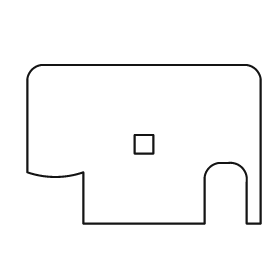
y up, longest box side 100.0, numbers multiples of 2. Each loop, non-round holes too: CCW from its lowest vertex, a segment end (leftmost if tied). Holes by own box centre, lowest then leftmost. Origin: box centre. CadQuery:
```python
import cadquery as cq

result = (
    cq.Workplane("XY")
    .moveTo(-26.0, -34.0)
    .lineTo(26.0, -34.0)
    .lineTo(26.0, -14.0)
    .threePointArc((28.0, -10.0), (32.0, -8.0))
    .lineTo(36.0, -8.0)
    .threePointArc((42.0, -10.0), (44.0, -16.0))
    .lineTo(44.0, -34.0)
    .lineTo(50.0, -34.0)
    .lineTo(50.0, 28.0)
    .threePointArc((48.0, 32.0), (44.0, 34.0))
    .lineTo(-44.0, 34.0)
    .threePointArc((-48.0, 32.0), (-50.0, 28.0))
    .lineTo(-50.0, -12.0)
    .threePointArc((-38.0, -14.0), (-26.0, -12.0))
    .close()
    .moveTo(-4.0, -4.0)
    .lineTo(4.0, -4.0)
    .lineTo(4.0, 4.0)
    .lineTo(-4.0, 4.0)
    .close()
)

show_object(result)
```